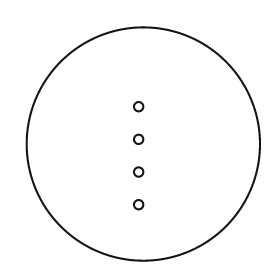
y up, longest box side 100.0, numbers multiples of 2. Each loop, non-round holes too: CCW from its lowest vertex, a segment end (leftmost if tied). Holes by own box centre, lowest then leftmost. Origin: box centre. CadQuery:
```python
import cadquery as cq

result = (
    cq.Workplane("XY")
    .moveTo(0.0, 0.0)
    .circle(50.0)
    .moveTo(-2.0, -26.0)
    .circle(2.0)
    .moveTo(-2.0, -12.0)
    .circle(2.0)
    .moveTo(-2.0, 2.0)
    .circle(2.0)
    .moveTo(-2.0, 16.0)
    .circle(2.0)
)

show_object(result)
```